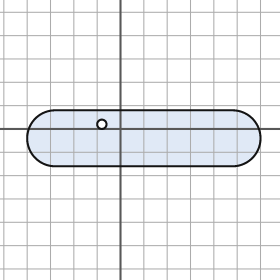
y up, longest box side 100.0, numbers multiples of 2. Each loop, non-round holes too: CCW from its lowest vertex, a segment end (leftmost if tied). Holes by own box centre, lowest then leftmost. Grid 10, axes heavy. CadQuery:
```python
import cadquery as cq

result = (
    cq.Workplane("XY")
    .moveTo(-28.0, -16.0)
    .lineTo(48.0, -16.0)
    .threePointArc((60.0, -4.0), (48.0, 8.0))
    .lineTo(-28.0, 8.0)
    .threePointArc((-40.0, -4.0), (-28.0, -16.0))
    .close()
    .moveTo(-8.0, 2.0)
    .circle(2.0)
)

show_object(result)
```